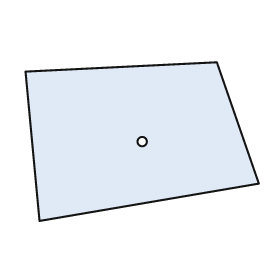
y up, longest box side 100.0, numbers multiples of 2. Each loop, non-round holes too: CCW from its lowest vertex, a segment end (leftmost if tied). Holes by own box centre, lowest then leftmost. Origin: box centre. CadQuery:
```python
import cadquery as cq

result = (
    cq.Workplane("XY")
    .moveTo(-44.0, -34.0)
    .lineTo(50.0, -18.0)
    .lineTo(32.0, 34.0)
    .lineTo(-50.0, 30.0)
    .close()
    .moveTo(0.0, 0.0)
    .circle(2.0)
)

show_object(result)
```